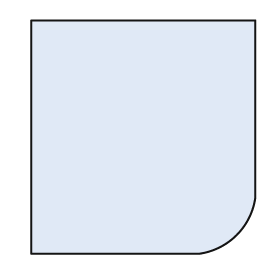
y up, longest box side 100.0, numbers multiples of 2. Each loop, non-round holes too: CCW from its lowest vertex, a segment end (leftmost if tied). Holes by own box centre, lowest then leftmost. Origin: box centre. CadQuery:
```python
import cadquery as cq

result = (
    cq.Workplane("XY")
    .moveTo(-48.0, -50.0)
    .lineTo(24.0, -50.0)
    .threePointArc((40.0, -42.0), (48.0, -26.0))
    .lineTo(48.0, 50.0)
    .lineTo(-48.0, 50.0)
    .close()
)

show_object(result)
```